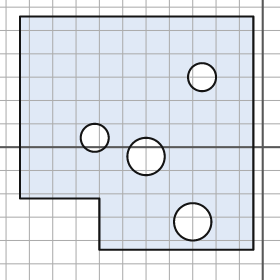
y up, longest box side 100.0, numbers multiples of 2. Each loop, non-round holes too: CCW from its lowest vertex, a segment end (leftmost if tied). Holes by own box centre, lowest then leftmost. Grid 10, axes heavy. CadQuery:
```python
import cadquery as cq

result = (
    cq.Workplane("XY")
    .moveTo(-70.0, -44.0)
    .lineTo(-4.0, -44.0)
    .lineTo(-4.0, 56.0)
    .lineTo(-104.0, 56.0)
    .lineTo(-104.0, -22.0)
    .lineTo(-70.0, -22.0)
    .close()
    .moveTo(-30.0, -32.0)
    .circle(8.0)
    .moveTo(-50.0, -4.0)
    .circle(8.0)
    .moveTo(-72.0, 4.0)
    .circle(6.0)
    .moveTo(-26.0, 30.0)
    .circle(6.0)
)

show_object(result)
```